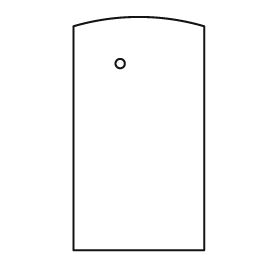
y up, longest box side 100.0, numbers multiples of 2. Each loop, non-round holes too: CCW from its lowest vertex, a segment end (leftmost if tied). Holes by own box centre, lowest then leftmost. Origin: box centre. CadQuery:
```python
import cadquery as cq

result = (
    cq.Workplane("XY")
    .moveTo(-28.0, -50.0)
    .lineTo(28.0, -50.0)
    .lineTo(28.0, 46.0)
    .threePointArc((0.0, 50.0), (-28.0, 46.0))
    .close()
    .moveTo(-8.0, 30.0)
    .circle(2.0)
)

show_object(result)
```